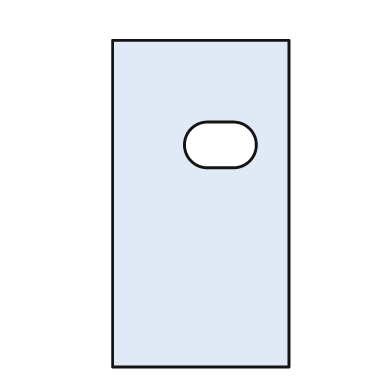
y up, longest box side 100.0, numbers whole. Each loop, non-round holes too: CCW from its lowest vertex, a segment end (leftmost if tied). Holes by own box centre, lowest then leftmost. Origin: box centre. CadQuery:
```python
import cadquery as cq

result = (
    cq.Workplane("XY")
    .moveTo(-27.0, -50.0)
    .lineTo(27.0, -50.0)
    .lineTo(27.0, 50.0)
    .lineTo(-27.0, 50.0)
    .close()
    .moveTo(2.0, 11.0)
    .lineTo(10.0, 11.0)
    .threePointArc((17.0, 18.0), (10.0, 25.0))
    .lineTo(2.0, 25.0)
    .threePointArc((-5.0, 18.0), (2.0, 11.0))
    .close()
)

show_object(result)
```